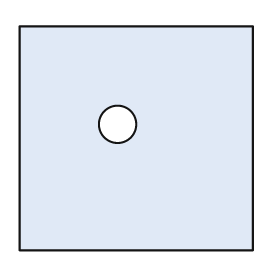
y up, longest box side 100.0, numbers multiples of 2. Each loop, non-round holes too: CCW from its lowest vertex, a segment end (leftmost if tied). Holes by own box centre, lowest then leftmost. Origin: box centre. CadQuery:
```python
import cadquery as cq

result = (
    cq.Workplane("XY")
    .moveTo(-50.0, -48.0)
    .lineTo(50.0, -48.0)
    .lineTo(50.0, 48.0)
    .lineTo(-50.0, 48.0)
    .close()
    .moveTo(-8.0, 6.0)
    .circle(8.0)
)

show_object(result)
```